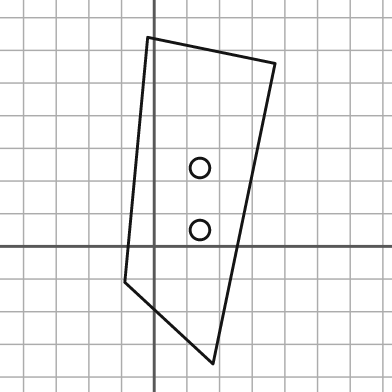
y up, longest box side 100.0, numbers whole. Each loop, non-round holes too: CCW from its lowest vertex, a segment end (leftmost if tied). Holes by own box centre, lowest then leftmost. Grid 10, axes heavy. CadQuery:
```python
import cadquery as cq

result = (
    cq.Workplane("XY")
    .moveTo(18.0, -36.0)
    .lineTo(37.0, 56.0)
    .lineTo(-2.0, 64.0)
    .lineTo(-9.0, -11.0)
    .close()
    .moveTo(14.0, 5.0)
    .circle(3.0)
    .moveTo(14.0, 24.0)
    .circle(3.0)
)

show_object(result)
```